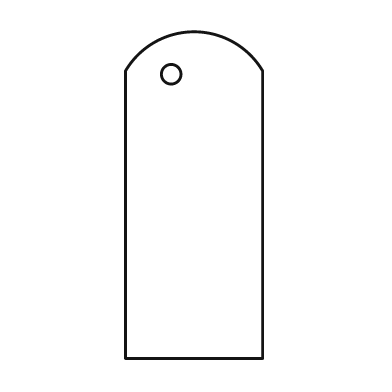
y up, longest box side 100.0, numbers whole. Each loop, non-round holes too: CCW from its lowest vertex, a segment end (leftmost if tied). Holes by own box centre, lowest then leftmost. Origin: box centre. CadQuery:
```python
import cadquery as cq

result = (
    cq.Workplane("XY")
    .moveTo(-21.0, -50.0)
    .lineTo(21.0, -50.0)
    .lineTo(21.0, 38.0)
    .threePointArc((0.0, 50.0), (-21.0, 38.0))
    .close()
    .moveTo(-7.0, 37.0)
    .circle(3.0)
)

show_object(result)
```